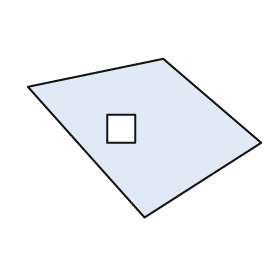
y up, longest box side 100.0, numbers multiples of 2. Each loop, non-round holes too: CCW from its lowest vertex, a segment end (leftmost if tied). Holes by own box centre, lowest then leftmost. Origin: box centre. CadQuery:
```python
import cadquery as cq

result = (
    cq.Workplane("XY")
    .moveTo(0.0, -34.0)
    .lineTo(50.0, -2.0)
    .lineTo(8.0, 34.0)
    .lineTo(-50.0, 22.0)
    .close()
    .moveTo(-16.0, -2.0)
    .lineTo(-4.0, -2.0)
    .lineTo(-4.0, 10.0)
    .lineTo(-16.0, 10.0)
    .close()
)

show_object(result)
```